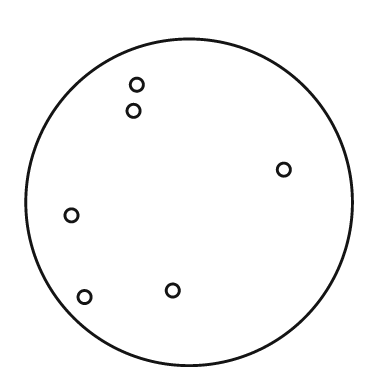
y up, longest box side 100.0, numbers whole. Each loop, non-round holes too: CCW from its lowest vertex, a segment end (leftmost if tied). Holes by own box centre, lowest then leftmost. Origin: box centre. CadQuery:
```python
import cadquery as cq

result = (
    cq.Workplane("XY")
    .moveTo(0.0, 0.0)
    .circle(50.0)
    .moveTo(-32.0, -29.0)
    .circle(2.0)
    .moveTo(-5.0, -27.0)
    .circle(2.0)
    .moveTo(-36.0, -4.0)
    .circle(2.0)
    .moveTo(29.0, 10.0)
    .circle(2.0)
    .moveTo(-17.0, 28.0)
    .circle(2.0)
    .moveTo(-16.0, 36.0)
    .circle(2.0)
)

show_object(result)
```